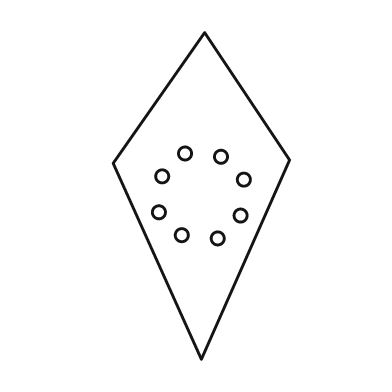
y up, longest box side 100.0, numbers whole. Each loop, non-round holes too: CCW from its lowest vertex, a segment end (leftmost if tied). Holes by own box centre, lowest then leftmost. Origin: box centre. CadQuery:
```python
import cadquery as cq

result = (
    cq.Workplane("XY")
    .moveTo(0.0, -50.0)
    .lineTo(27.0, 11.0)
    .lineTo(1.0, 50.0)
    .lineTo(-27.0, 10.0)
    .close()
    .moveTo(5.0, -13.0)
    .circle(2.0)
    .moveTo(-6.0, -12.0)
    .circle(2.0)
    .moveTo(12.0, -6.0)
    .circle(2.0)
    .moveTo(-13.0, -5.0)
    .circle(2.0)
    .moveTo(13.0, 5.0)
    .circle(2.0)
    .moveTo(-12.0, 6.0)
    .circle(2.0)
    .moveTo(6.0, 12.0)
    .circle(2.0)
    .moveTo(-5.0, 13.0)
    .circle(2.0)
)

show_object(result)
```